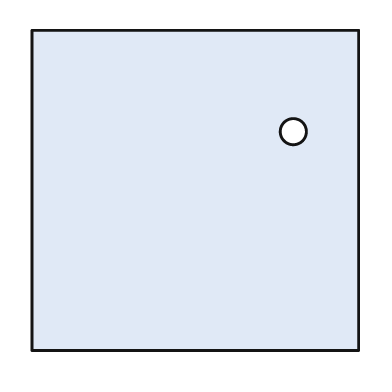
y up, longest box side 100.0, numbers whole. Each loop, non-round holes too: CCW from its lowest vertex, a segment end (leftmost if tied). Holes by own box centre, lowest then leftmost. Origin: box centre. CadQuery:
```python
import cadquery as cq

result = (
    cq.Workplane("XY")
    .moveTo(-50.0, -49.0)
    .lineTo(50.0, -49.0)
    .lineTo(50.0, 49.0)
    .lineTo(-50.0, 49.0)
    .close()
    .moveTo(30.0, 18.0)
    .circle(4.0)
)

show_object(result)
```